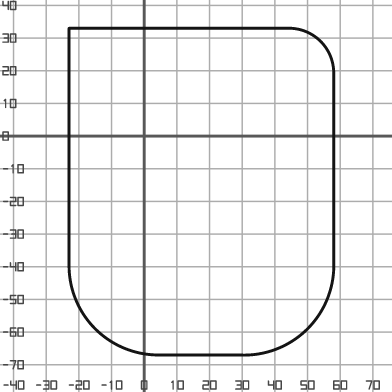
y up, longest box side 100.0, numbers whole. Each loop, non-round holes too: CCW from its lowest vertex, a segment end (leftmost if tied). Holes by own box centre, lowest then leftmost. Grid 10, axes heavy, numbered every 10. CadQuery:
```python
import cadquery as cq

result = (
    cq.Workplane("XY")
    .moveTo(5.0, -67.0)
    .lineTo(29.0, -67.0)
    .threePointArc((50.0, -59.0), (58.0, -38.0))
    .lineTo(58.0, 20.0)
    .threePointArc((54.0, 29.0), (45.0, 33.0))
    .lineTo(-23.0, 33.0)
    .lineTo(-23.0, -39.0)
    .threePointArc((-15.0, -59.0), (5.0, -67.0))
    .close()
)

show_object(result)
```